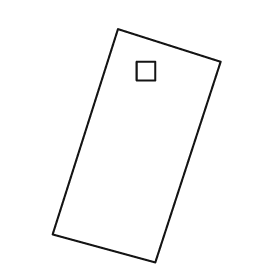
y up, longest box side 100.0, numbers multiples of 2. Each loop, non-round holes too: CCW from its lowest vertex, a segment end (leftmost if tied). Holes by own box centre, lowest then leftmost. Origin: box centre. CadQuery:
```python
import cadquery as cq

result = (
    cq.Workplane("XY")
    .moveTo(8.0, -50.0)
    .lineTo(36.0, 36.0)
    .lineTo(-8.0, 50.0)
    .lineTo(-36.0, -38.0)
    .close()
    .moveTo(0.0, 28.0)
    .lineTo(8.0, 28.0)
    .lineTo(8.0, 36.0)
    .lineTo(0.0, 36.0)
    .close()
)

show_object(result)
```